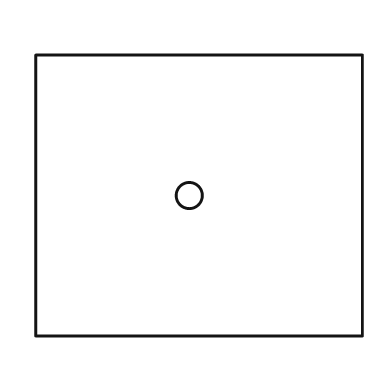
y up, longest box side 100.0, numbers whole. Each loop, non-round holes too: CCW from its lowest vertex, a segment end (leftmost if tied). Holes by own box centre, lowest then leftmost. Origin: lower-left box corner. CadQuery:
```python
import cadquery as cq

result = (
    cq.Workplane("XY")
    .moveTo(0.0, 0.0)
    .lineTo(100.0, 0.0)
    .lineTo(100.0, 86.0)
    .lineTo(0.0, 86.0)
    .close()
    .moveTo(47.0, 43.0)
    .circle(4.0)
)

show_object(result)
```